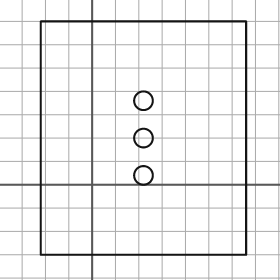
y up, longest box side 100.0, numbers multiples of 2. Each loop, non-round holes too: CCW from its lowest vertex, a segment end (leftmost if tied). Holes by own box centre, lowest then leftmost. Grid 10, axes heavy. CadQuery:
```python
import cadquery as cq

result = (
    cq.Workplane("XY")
    .moveTo(-22.0, -30.0)
    .lineTo(66.0, -30.0)
    .lineTo(66.0, 70.0)
    .lineTo(-22.0, 70.0)
    .close()
    .moveTo(22.0, 4.0)
    .circle(4.0)
    .moveTo(22.0, 20.0)
    .circle(4.0)
    .moveTo(22.0, 36.0)
    .circle(4.0)
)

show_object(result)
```